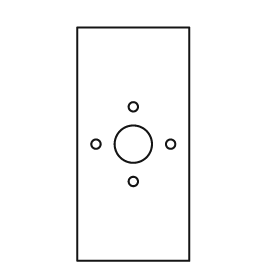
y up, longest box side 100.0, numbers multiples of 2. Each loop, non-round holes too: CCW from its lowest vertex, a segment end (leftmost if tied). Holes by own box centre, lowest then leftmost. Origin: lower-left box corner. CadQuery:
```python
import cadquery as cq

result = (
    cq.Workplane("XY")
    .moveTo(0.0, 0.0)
    .lineTo(48.0, 0.0)
    .lineTo(48.0, 100.0)
    .lineTo(0.0, 100.0)
    .close()
    .moveTo(24.0, 34.0)
    .circle(2.0)
    .moveTo(8.0, 50.0)
    .circle(2.0)
    .moveTo(24.0, 50.0)
    .circle(8.0)
    .moveTo(40.0, 50.0)
    .circle(2.0)
    .moveTo(24.0, 66.0)
    .circle(2.0)
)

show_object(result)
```